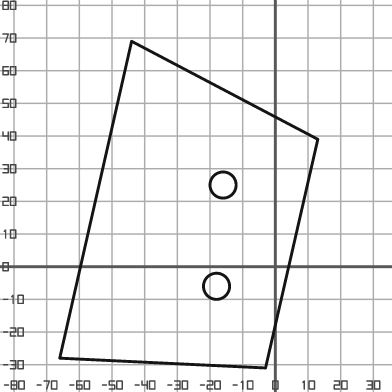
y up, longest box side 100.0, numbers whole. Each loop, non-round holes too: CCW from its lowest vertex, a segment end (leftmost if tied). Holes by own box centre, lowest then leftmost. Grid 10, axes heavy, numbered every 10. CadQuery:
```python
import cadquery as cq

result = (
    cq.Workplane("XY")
    .moveTo(-3.0, -31.0)
    .lineTo(13.0, 39.0)
    .lineTo(-44.0, 69.0)
    .lineTo(-66.0, -28.0)
    .close()
    .moveTo(-18.0, -6.0)
    .circle(4.0)
    .moveTo(-16.0, 25.0)
    .circle(4.0)
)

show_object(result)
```